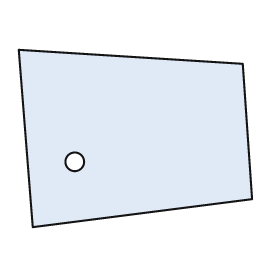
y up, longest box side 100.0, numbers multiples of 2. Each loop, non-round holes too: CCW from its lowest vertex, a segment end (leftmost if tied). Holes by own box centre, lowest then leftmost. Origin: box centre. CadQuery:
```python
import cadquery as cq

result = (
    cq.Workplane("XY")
    .moveTo(-44.0, -38.0)
    .lineTo(50.0, -26.0)
    .lineTo(46.0, 32.0)
    .lineTo(-50.0, 38.0)
    .close()
    .moveTo(-26.0, -10.0)
    .circle(4.0)
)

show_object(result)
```